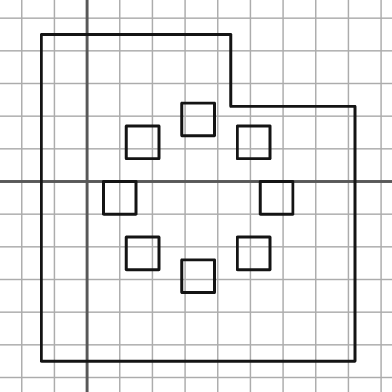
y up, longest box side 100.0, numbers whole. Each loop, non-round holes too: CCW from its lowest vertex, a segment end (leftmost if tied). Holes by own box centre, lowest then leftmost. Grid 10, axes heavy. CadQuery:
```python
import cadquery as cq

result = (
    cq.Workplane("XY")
    .moveTo(-14.0, -55.0)
    .lineTo(82.0, -55.0)
    .lineTo(82.0, 23.0)
    .lineTo(44.0, 23.0)
    .lineTo(44.0, 45.0)
    .lineTo(-14.0, 45.0)
    .close()
    .moveTo(29.0, -34.0)
    .lineTo(39.0, -34.0)
    .lineTo(39.0, -24.0)
    .lineTo(29.0, -24.0)
    .close()
    .moveTo(12.0, -27.0)
    .lineTo(22.0, -27.0)
    .lineTo(22.0, -17.0)
    .lineTo(12.0, -17.0)
    .close()
    .moveTo(46.0, -27.0)
    .lineTo(56.0, -27.0)
    .lineTo(56.0, -17.0)
    .lineTo(46.0, -17.0)
    .close()
    .moveTo(5.0, -10.0)
    .lineTo(15.0, -10.0)
    .lineTo(15.0, 0.0)
    .lineTo(5.0, 0.0)
    .close()
    .moveTo(53.0, -10.0)
    .lineTo(63.0, -10.0)
    .lineTo(63.0, 0.0)
    .lineTo(53.0, 0.0)
    .close()
    .moveTo(12.0, 7.0)
    .lineTo(22.0, 7.0)
    .lineTo(22.0, 17.0)
    .lineTo(12.0, 17.0)
    .close()
    .moveTo(46.0, 7.0)
    .lineTo(56.0, 7.0)
    .lineTo(56.0, 17.0)
    .lineTo(46.0, 17.0)
    .close()
    .moveTo(29.0, 14.0)
    .lineTo(39.0, 14.0)
    .lineTo(39.0, 24.0)
    .lineTo(29.0, 24.0)
    .close()
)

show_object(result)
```